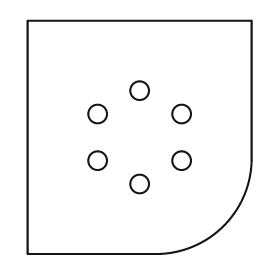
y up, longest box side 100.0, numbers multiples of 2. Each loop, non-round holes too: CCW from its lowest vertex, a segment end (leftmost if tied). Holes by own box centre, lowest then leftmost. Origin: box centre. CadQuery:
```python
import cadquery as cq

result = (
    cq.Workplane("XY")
    .moveTo(-48.0, -50.0)
    .lineTo(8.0, -50.0)
    .threePointArc((36.0, -38.0), (48.0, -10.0))
    .lineTo(48.0, 50.0)
    .lineTo(-48.0, 50.0)
    .close()
    .moveTo(0.0, -20.0)
    .circle(4.0)
    .moveTo(-18.0, -10.0)
    .circle(4.0)
    .moveTo(18.0, -10.0)
    .circle(4.0)
    .moveTo(-18.0, 10.0)
    .circle(4.0)
    .moveTo(18.0, 10.0)
    .circle(4.0)
    .moveTo(0.0, 20.0)
    .circle(4.0)
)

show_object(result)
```